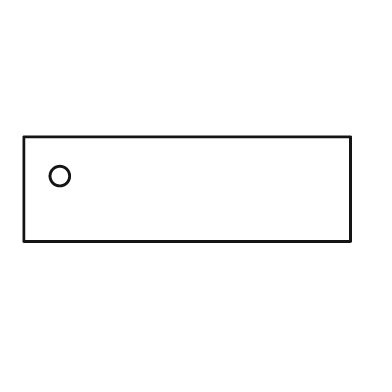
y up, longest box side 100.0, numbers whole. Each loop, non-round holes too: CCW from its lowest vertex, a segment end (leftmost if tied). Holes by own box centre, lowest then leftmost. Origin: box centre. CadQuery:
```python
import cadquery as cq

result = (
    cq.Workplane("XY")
    .moveTo(-50.0, -16.0)
    .lineTo(50.0, -16.0)
    .lineTo(50.0, 16.0)
    .lineTo(-50.0, 16.0)
    .close()
    .moveTo(-39.0, 4.0)
    .circle(3.0)
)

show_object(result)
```